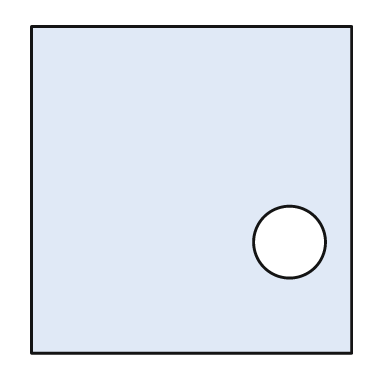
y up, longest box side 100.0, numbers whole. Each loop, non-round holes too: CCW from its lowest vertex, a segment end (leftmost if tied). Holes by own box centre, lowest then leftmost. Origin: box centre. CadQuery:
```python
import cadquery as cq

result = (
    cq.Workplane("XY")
    .moveTo(-49.0, -50.0)
    .lineTo(49.0, -50.0)
    .lineTo(49.0, 50.0)
    .lineTo(-49.0, 50.0)
    .close()
    .moveTo(30.0, -16.0)
    .circle(11.0)
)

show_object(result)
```